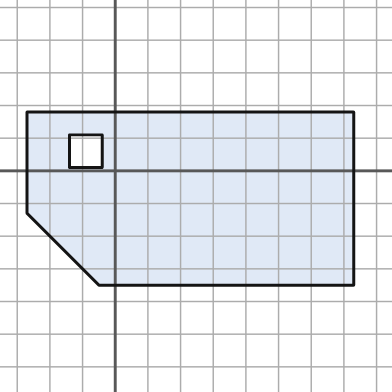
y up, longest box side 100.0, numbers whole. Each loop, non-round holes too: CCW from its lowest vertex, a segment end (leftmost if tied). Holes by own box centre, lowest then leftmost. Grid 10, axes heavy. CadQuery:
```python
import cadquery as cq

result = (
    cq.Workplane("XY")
    .moveTo(-5.0, -35.0)
    .lineTo(73.0, -35.0)
    .lineTo(73.0, 18.0)
    .lineTo(-27.0, 18.0)
    .lineTo(-27.0, -13.0)
    .close()
    .moveTo(-14.0, 1.0)
    .lineTo(-4.0, 1.0)
    .lineTo(-4.0, 11.0)
    .lineTo(-14.0, 11.0)
    .close()
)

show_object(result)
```